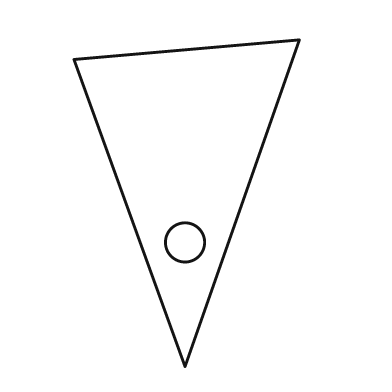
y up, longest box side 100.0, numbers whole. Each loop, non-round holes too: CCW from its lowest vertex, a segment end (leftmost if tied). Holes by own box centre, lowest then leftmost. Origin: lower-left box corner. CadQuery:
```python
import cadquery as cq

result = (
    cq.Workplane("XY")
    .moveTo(34.0, 0.0)
    .lineTo(69.0, 100.0)
    .lineTo(0.0, 94.0)
    .close()
    .moveTo(34.0, 38.0)
    .circle(6.0)
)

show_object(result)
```